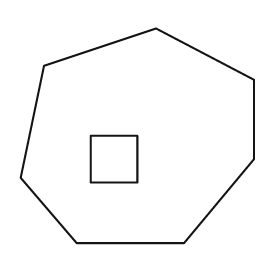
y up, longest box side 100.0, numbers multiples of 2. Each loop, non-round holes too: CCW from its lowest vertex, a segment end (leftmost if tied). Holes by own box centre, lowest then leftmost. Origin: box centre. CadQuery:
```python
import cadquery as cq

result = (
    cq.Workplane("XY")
    .moveTo(-26.0, -46.0)
    .lineTo(20.0, -46.0)
    .lineTo(50.0, -10.0)
    .lineTo(50.0, 24.0)
    .lineTo(8.0, 46.0)
    .lineTo(-40.0, 30.0)
    .lineTo(-50.0, -18.0)
    .close()
    .moveTo(-20.0, -20.0)
    .lineTo(0.0, -20.0)
    .lineTo(0.0, 0.0)
    .lineTo(-20.0, 0.0)
    .close()
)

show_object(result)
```